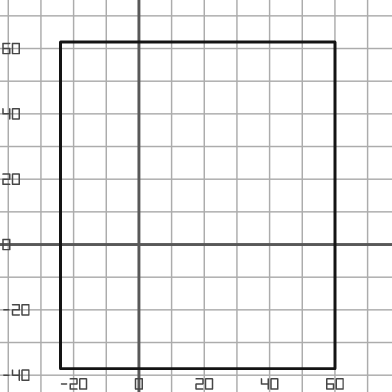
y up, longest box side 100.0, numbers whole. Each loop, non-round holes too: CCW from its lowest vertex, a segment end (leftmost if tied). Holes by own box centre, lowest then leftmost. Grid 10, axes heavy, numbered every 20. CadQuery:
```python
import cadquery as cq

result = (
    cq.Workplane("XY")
    .moveTo(-24.0, -38.0)
    .lineTo(60.0, -38.0)
    .lineTo(60.0, 62.0)
    .lineTo(-24.0, 62.0)
    .close()
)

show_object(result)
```